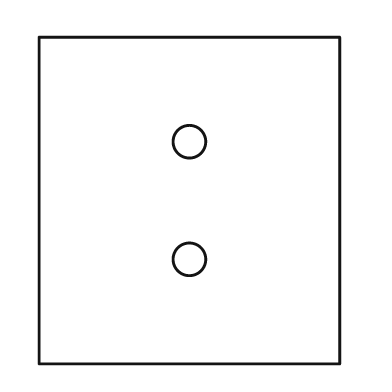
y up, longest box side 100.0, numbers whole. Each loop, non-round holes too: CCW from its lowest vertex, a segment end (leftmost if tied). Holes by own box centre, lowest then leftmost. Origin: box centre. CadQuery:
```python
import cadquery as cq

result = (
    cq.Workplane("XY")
    .moveTo(-46.0, -50.0)
    .lineTo(46.0, -50.0)
    .lineTo(46.0, 50.0)
    .lineTo(-46.0, 50.0)
    .close()
    .moveTo(0.0, -18.0)
    .circle(5.0)
    .moveTo(0.0, 18.0)
    .circle(5.0)
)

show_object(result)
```